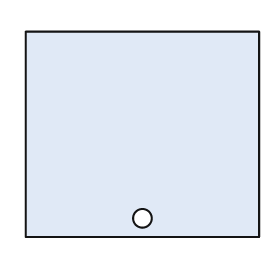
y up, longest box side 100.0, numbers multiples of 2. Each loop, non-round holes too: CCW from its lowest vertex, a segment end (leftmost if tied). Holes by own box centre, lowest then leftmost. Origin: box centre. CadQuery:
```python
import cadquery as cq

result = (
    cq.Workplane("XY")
    .moveTo(-50.0, -44.0)
    .lineTo(50.0, -44.0)
    .lineTo(50.0, 44.0)
    .lineTo(-50.0, 44.0)
    .close()
    .moveTo(0.0, -36.0)
    .circle(4.0)
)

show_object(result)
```